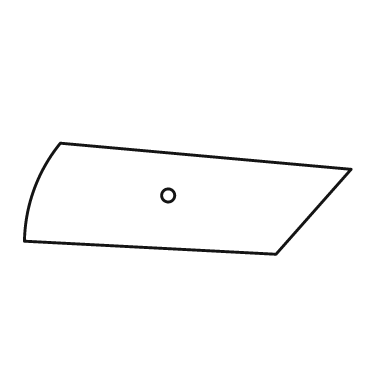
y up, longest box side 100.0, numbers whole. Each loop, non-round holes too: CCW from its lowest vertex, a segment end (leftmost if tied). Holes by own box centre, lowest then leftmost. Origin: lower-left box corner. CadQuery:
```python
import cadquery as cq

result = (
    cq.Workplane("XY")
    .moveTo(77.0, 0.0)
    .lineTo(100.0, 26.0)
    .lineTo(11.0, 34.0)
    .threePointArc((3.0, 20.0), (0.0, 4.0))
    .close()
    .moveTo(44.0, 18.0)
    .circle(2.0)
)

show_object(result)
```